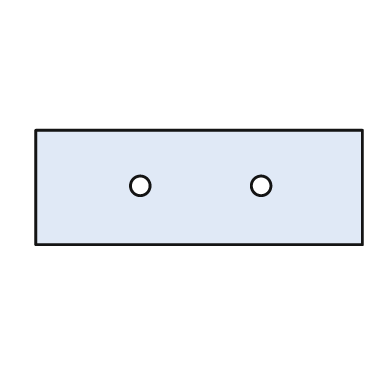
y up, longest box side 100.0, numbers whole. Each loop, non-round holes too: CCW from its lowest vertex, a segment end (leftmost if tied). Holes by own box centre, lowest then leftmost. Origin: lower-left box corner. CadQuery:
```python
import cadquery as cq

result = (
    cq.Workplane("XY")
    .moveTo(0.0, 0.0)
    .lineTo(100.0, 0.0)
    .lineTo(100.0, 35.0)
    .lineTo(0.0, 35.0)
    .close()
    .moveTo(32.0, 18.0)
    .circle(3.0)
    .moveTo(69.0, 18.0)
    .circle(3.0)
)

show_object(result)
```